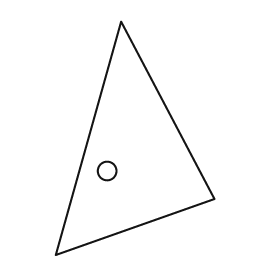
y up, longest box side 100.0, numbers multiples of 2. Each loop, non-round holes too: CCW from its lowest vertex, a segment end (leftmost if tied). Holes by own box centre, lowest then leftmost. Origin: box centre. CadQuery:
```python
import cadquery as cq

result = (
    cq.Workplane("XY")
    .moveTo(-34.0, -50.0)
    .lineTo(34.0, -26.0)
    .lineTo(-6.0, 50.0)
    .close()
    .moveTo(-12.0, -14.0)
    .circle(4.0)
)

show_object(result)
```